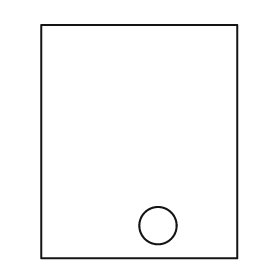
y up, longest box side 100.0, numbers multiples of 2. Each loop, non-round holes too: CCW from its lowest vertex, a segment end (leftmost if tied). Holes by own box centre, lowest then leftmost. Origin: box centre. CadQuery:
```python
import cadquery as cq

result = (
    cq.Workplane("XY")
    .moveTo(-42.0, -50.0)
    .lineTo(42.0, -50.0)
    .lineTo(42.0, 50.0)
    .lineTo(-42.0, 50.0)
    .close()
    .moveTo(8.0, -36.0)
    .circle(8.0)
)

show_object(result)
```